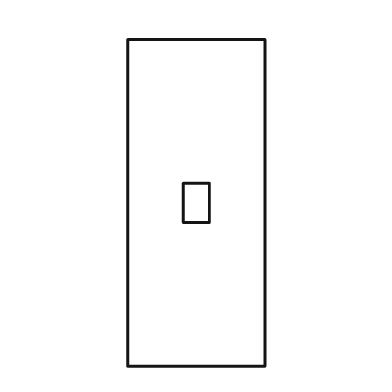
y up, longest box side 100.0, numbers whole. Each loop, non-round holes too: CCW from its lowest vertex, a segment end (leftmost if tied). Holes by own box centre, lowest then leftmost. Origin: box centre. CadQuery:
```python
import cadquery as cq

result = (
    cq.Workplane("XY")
    .moveTo(-21.0, -50.0)
    .lineTo(21.0, -50.0)
    .lineTo(21.0, 50.0)
    .lineTo(-21.0, 50.0)
    .close()
    .moveTo(-4.0, -6.0)
    .lineTo(4.0, -6.0)
    .lineTo(4.0, 6.0)
    .lineTo(-4.0, 6.0)
    .close()
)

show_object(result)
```